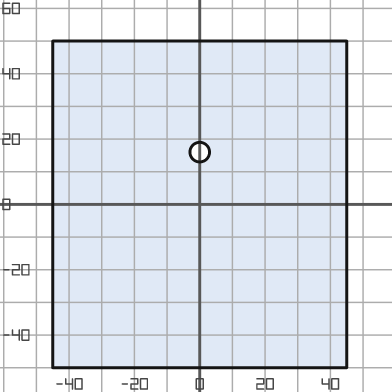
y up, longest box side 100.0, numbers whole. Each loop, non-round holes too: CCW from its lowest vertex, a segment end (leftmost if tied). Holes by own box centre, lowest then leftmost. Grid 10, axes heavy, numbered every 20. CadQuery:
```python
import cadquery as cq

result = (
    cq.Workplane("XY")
    .moveTo(-45.0, -50.0)
    .lineTo(45.0, -50.0)
    .lineTo(45.0, 50.0)
    .lineTo(-45.0, 50.0)
    .close()
    .moveTo(0.0, 16.0)
    .circle(3.0)
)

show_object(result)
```